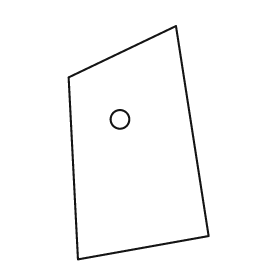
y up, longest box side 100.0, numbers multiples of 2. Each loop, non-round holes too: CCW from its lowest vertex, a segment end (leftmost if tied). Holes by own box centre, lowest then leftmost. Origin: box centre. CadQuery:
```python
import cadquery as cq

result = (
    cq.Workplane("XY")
    .moveTo(-26.0, -50.0)
    .lineTo(30.0, -40.0)
    .lineTo(16.0, 50.0)
    .lineTo(-30.0, 28.0)
    .close()
    .moveTo(-8.0, 10.0)
    .circle(4.0)
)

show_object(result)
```